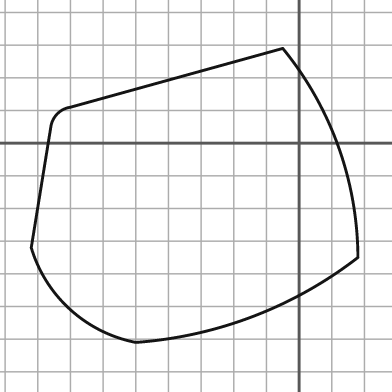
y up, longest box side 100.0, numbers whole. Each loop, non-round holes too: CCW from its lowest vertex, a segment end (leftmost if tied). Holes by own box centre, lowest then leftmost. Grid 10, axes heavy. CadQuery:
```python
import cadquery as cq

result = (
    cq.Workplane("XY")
    .moveTo(-50.0, -61.0)
    .threePointArc((-14.0, -53.0), (18.0, -35.0))
    .threePointArc((12.0, -1.0), (-5.0, 29.0))
    .lineTo(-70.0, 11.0)
    .threePointArc((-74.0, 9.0), (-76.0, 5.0))
    .lineTo(-82.0, -32.0)
    .threePointArc((-70.0, -51.0), (-50.0, -61.0))
    .close()
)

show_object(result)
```